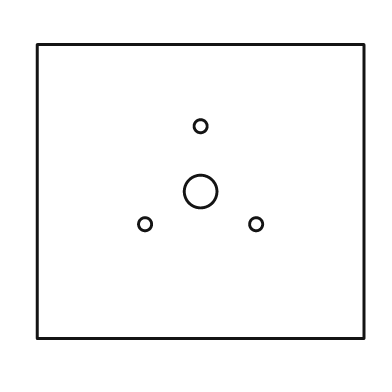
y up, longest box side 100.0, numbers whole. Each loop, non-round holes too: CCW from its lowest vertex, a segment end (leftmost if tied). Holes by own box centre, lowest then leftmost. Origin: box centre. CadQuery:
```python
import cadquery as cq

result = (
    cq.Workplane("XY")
    .moveTo(-50.0, -45.0)
    .lineTo(50.0, -45.0)
    .lineTo(50.0, 45.0)
    .lineTo(-50.0, 45.0)
    .close()
    .moveTo(-17.0, -10.0)
    .circle(2.0)
    .moveTo(17.0, -10.0)
    .circle(2.0)
    .moveTo(0.0, 0.0)
    .circle(5.0)
    .moveTo(0.0, 20.0)
    .circle(2.0)
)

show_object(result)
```